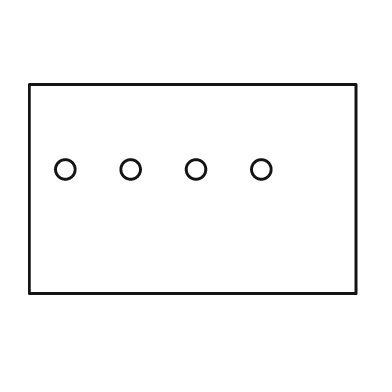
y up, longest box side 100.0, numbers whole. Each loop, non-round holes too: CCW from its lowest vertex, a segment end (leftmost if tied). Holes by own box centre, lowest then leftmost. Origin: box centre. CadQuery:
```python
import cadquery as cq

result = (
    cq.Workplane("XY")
    .moveTo(-50.0, -32.0)
    .lineTo(50.0, -32.0)
    .lineTo(50.0, 32.0)
    .lineTo(-50.0, 32.0)
    .close()
    .moveTo(-39.0, 6.0)
    .circle(3.0)
    .moveTo(-19.0, 6.0)
    .circle(3.0)
    .moveTo(1.0, 6.0)
    .circle(3.0)
    .moveTo(21.0, 6.0)
    .circle(3.0)
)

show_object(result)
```